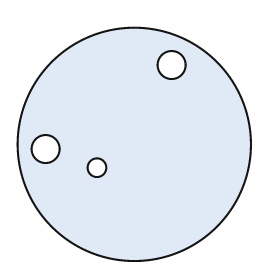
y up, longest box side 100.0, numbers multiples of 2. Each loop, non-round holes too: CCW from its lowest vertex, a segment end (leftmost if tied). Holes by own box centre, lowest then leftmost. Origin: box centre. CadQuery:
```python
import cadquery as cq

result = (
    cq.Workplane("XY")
    .moveTo(0.0, 0.0)
    .circle(50.0)
    .moveTo(-16.0, -10.0)
    .circle(4.0)
    .moveTo(-38.0, -2.0)
    .circle(6.0)
    .moveTo(16.0, 34.0)
    .circle(6.0)
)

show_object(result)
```